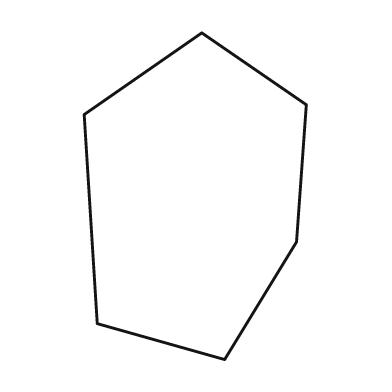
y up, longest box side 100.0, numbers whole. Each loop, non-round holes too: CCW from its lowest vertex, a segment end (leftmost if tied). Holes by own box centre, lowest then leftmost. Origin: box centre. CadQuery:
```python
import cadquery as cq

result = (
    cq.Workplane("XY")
    .moveTo(9.0, -50.0)
    .lineTo(31.0, -14.0)
    .lineTo(34.0, 28.0)
    .lineTo(2.0, 50.0)
    .lineTo(-34.0, 25.0)
    .lineTo(-30.0, -39.0)
    .close()
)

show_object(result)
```